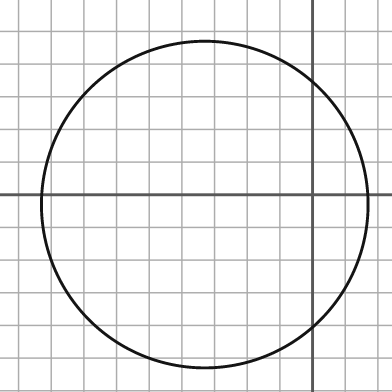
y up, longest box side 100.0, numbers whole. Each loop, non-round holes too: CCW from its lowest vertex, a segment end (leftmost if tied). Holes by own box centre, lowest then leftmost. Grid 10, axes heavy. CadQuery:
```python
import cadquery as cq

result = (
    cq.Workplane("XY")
    .moveTo(-33.0, -3.0)
    .circle(50.0)
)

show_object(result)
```